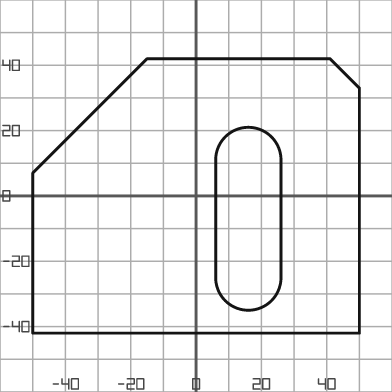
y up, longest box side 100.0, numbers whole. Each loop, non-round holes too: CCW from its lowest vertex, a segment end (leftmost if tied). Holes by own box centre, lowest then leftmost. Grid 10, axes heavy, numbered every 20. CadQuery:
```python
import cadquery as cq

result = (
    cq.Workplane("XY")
    .moveTo(-50.0, -42.0)
    .lineTo(50.0, -42.0)
    .lineTo(50.0, 33.0)
    .lineTo(41.0, 42.0)
    .lineTo(-15.0, 42.0)
    .lineTo(-50.0, 7.0)
    .close()
    .moveTo(6.0, -25.0)
    .threePointArc((16.0, -35.0), (26.0, -25.0))
    .lineTo(26.0, 11.0)
    .threePointArc((16.0, 21.0), (6.0, 11.0))
    .close()
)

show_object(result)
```